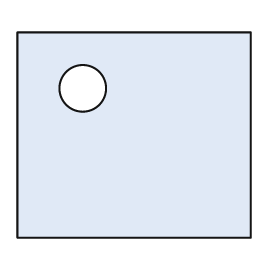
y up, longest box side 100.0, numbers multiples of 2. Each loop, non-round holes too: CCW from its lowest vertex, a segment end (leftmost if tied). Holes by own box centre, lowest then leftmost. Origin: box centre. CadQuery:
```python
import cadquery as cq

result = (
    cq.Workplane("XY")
    .moveTo(-50.0, -44.0)
    .lineTo(50.0, -44.0)
    .lineTo(50.0, 44.0)
    .lineTo(-50.0, 44.0)
    .close()
    .moveTo(-22.0, 20.0)
    .circle(10.0)
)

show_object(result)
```